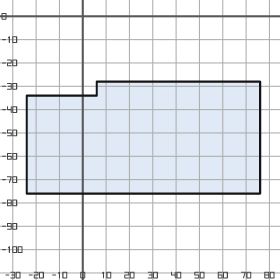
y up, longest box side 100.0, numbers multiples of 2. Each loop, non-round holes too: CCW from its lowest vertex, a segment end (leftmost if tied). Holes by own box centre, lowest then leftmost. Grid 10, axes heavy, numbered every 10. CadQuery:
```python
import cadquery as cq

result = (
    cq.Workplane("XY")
    .moveTo(-24.0, -76.0)
    .lineTo(76.0, -76.0)
    .lineTo(76.0, -28.0)
    .lineTo(6.0, -28.0)
    .lineTo(6.0, -34.0)
    .lineTo(-24.0, -34.0)
    .close()
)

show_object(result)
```